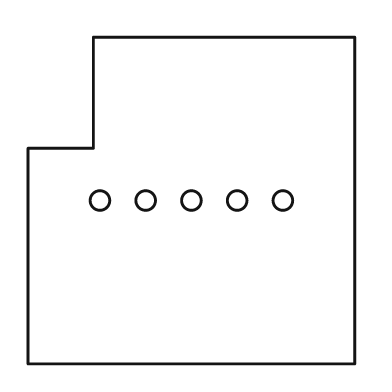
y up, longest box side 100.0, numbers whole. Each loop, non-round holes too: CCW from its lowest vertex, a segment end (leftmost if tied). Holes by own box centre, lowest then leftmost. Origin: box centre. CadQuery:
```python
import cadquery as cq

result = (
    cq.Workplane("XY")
    .moveTo(-50.0, -50.0)
    .lineTo(50.0, -50.0)
    .lineTo(50.0, 50.0)
    .lineTo(-30.0, 50.0)
    .lineTo(-30.0, 16.0)
    .lineTo(-50.0, 16.0)
    .close()
    .moveTo(-28.0, 0.0)
    .circle(3.0)
    .moveTo(-14.0, 0.0)
    .circle(3.0)
    .moveTo(0.0, 0.0)
    .circle(3.0)
    .moveTo(14.0, 0.0)
    .circle(3.0)
    .moveTo(28.0, 0.0)
    .circle(3.0)
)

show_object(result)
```